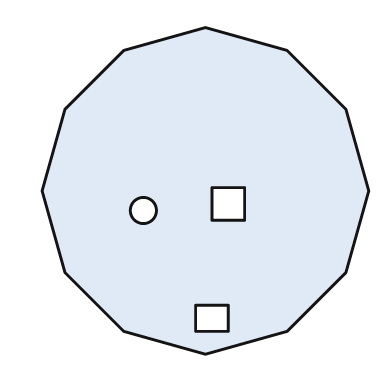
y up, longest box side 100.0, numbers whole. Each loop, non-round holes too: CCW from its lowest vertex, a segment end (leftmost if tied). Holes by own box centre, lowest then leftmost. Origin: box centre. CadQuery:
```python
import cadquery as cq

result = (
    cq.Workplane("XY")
    .moveTo(0.0, -50.0)
    .lineTo(25.0, -43.0)
    .lineTo(43.0, -25.0)
    .lineTo(50.0, 0.0)
    .lineTo(43.0, 25.0)
    .lineTo(25.0, 43.0)
    .lineTo(0.0, 50.0)
    .lineTo(-25.0, 43.0)
    .lineTo(-43.0, 25.0)
    .lineTo(-50.0, 0.0)
    .lineTo(-43.0, -25.0)
    .lineTo(-25.0, -43.0)
    .close()
    .moveTo(-3.0, -43.0)
    .lineTo(7.0, -43.0)
    .lineTo(7.0, -35.0)
    .lineTo(-3.0, -35.0)
    .close()
    .moveTo(-19.0, -6.0)
    .circle(4.0)
    .moveTo(2.0, -9.0)
    .lineTo(12.0, -9.0)
    .lineTo(12.0, 1.0)
    .lineTo(2.0, 1.0)
    .close()
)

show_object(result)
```